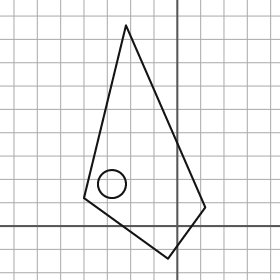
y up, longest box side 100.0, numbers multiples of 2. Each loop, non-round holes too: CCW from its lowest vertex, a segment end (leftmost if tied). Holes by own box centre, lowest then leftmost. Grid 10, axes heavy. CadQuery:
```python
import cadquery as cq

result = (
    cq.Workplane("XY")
    .moveTo(-4.0, -14.0)
    .lineTo(12.0, 8.0)
    .lineTo(-22.0, 86.0)
    .lineTo(-40.0, 12.0)
    .close()
    .moveTo(-28.0, 18.0)
    .circle(6.0)
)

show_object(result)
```